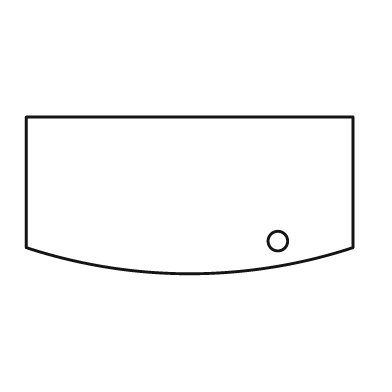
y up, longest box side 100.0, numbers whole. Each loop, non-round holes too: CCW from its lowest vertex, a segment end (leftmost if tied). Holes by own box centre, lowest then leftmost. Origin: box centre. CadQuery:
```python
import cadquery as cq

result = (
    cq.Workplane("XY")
    .moveTo(-50.0, -16.0)
    .threePointArc((0.0, -24.0), (50.0, -16.0))
    .lineTo(50.0, 24.0)
    .lineTo(-50.0, 24.0)
    .close()
    .moveTo(27.0, -14.0)
    .circle(3.0)
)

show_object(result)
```